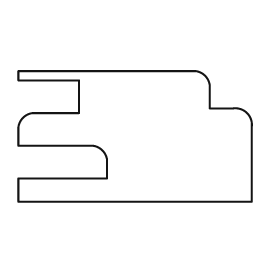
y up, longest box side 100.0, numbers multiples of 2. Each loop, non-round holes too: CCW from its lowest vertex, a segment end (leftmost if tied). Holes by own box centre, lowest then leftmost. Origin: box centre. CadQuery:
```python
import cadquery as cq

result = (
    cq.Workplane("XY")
    .moveTo(-50.0, -28.0)
    .lineTo(50.0, -28.0)
    .lineTo(50.0, 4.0)
    .threePointArc((48.0, 10.0), (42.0, 12.0))
    .lineTo(32.0, 12.0)
    .lineTo(32.0, 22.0)
    .threePointArc((30.0, 26.0), (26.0, 28.0))
    .lineTo(-50.0, 28.0)
    .lineTo(-50.0, 24.0)
    .lineTo(-24.0, 24.0)
    .lineTo(-24.0, 10.0)
    .lineTo(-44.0, 10.0)
    .threePointArc((-48.0, 8.0), (-50.0, 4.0))
    .lineTo(-50.0, -4.0)
    .lineTo(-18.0, -4.0)
    .threePointArc((-14.0, -6.0), (-12.0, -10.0))
    .lineTo(-12.0, -18.0)
    .lineTo(-50.0, -18.0)
    .close()
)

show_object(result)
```